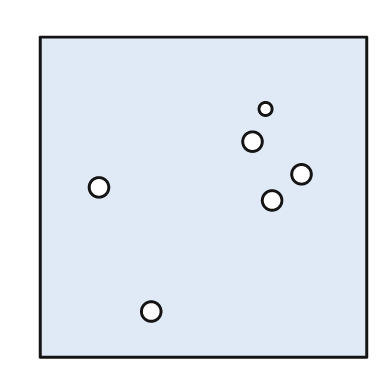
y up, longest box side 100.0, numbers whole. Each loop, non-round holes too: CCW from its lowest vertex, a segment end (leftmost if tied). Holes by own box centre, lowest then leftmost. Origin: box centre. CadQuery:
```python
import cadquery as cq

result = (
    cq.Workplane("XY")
    .moveTo(-50.0, -49.0)
    .lineTo(50.0, -49.0)
    .lineTo(50.0, 49.0)
    .lineTo(-50.0, 49.0)
    .close()
    .moveTo(-16.0, -35.0)
    .circle(3.0)
    .moveTo(21.0, -1.0)
    .circle(3.0)
    .moveTo(-32.0, 3.0)
    .circle(3.0)
    .moveTo(30.0, 7.0)
    .circle(3.0)
    .moveTo(15.0, 17.0)
    .circle(3.0)
    .moveTo(19.0, 27.0)
    .circle(2.0)
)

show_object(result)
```